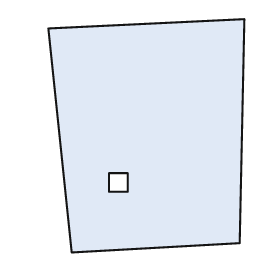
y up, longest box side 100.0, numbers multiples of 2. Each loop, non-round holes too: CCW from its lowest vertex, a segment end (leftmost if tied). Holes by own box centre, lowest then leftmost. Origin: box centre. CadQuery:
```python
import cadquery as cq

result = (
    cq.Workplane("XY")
    .moveTo(-32.0, -50.0)
    .lineTo(40.0, -46.0)
    .lineTo(42.0, 50.0)
    .lineTo(-42.0, 46.0)
    .close()
    .moveTo(-16.0, -24.0)
    .lineTo(-8.0, -24.0)
    .lineTo(-8.0, -16.0)
    .lineTo(-16.0, -16.0)
    .close()
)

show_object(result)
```